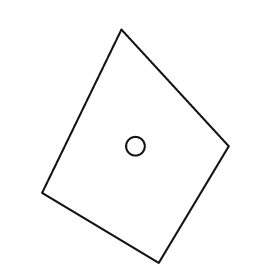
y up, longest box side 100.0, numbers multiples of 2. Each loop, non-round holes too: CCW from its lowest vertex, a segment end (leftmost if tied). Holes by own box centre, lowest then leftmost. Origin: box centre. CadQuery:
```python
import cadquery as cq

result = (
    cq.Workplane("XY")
    .moveTo(10.0, -50.0)
    .lineTo(40.0, 0.0)
    .lineTo(-6.0, 50.0)
    .lineTo(-40.0, -20.0)
    .close()
    .moveTo(0.0, 0.0)
    .circle(4.0)
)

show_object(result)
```